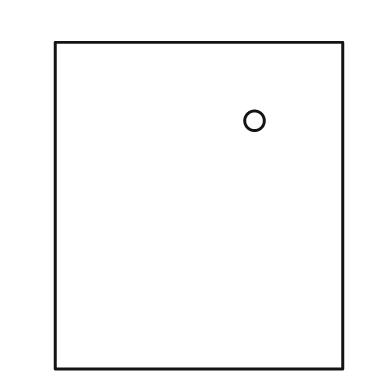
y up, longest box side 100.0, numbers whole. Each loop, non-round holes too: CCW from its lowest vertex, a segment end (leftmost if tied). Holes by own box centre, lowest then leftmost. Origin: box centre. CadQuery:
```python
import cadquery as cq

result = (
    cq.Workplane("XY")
    .moveTo(-44.0, -50.0)
    .lineTo(44.0, -50.0)
    .lineTo(44.0, 50.0)
    .lineTo(-44.0, 50.0)
    .close()
    .moveTo(17.0, 26.0)
    .circle(3.0)
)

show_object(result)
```